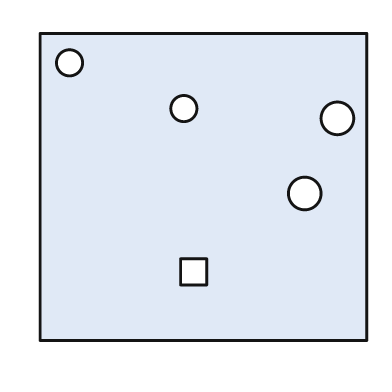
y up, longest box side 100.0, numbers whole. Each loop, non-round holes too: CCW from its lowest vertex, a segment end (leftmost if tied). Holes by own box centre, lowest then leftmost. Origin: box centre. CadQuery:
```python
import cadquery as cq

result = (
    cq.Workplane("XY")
    .moveTo(-50.0, -47.0)
    .lineTo(50.0, -47.0)
    .lineTo(50.0, 47.0)
    .lineTo(-50.0, 47.0)
    .close()
    .moveTo(-7.0, -30.0)
    .lineTo(1.0, -30.0)
    .lineTo(1.0, -22.0)
    .lineTo(-7.0, -22.0)
    .close()
    .moveTo(31.0, -2.0)
    .circle(5.0)
    .moveTo(41.0, 21.0)
    .circle(5.0)
    .moveTo(-6.0, 24.0)
    .circle(4.0)
    .moveTo(-41.0, 38.0)
    .circle(4.0)
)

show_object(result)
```